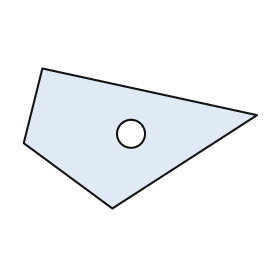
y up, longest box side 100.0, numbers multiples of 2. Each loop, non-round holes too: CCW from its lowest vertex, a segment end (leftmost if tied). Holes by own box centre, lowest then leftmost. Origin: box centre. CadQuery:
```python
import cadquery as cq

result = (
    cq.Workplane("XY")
    .moveTo(-12.0, -30.0)
    .lineTo(50.0, 10.0)
    .lineTo(-42.0, 30.0)
    .lineTo(-50.0, -2.0)
    .close()
    .moveTo(-4.0, 2.0)
    .circle(6.0)
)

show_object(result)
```